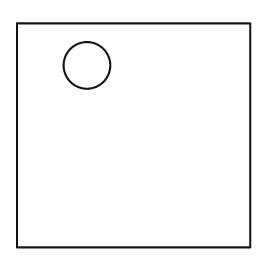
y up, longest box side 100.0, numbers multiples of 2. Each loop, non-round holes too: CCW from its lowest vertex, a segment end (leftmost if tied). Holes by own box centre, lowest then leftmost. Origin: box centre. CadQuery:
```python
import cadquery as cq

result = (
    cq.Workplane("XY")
    .moveTo(-50.0, -48.0)
    .lineTo(50.0, -48.0)
    .lineTo(50.0, 48.0)
    .lineTo(-50.0, 48.0)
    .close()
    .moveTo(-20.0, 30.0)
    .circle(10.0)
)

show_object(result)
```